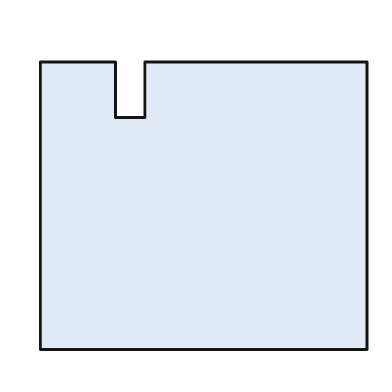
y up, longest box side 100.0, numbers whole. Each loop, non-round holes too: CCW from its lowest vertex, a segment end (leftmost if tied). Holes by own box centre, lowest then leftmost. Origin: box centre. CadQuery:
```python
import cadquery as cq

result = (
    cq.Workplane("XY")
    .moveTo(-50.0, -44.0)
    .lineTo(50.0, -44.0)
    .lineTo(50.0, 44.0)
    .lineTo(-18.0, 44.0)
    .lineTo(-18.0, 27.0)
    .lineTo(-27.0, 27.0)
    .lineTo(-27.0, 44.0)
    .lineTo(-50.0, 44.0)
    .close()
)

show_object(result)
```